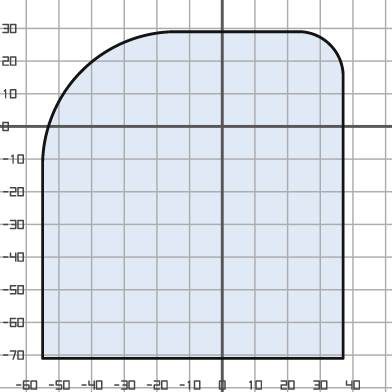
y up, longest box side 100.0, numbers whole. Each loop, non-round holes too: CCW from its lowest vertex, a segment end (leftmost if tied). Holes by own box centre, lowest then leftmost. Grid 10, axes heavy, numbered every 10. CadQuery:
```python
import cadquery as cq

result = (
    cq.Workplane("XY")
    .moveTo(-55.0, -71.0)
    .lineTo(37.0, -71.0)
    .lineTo(37.0, 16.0)
    .threePointArc((33.0, 25.0), (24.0, 29.0))
    .lineTo(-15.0, 29.0)
    .threePointArc((-43.0, 17.0), (-55.0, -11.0))
    .close()
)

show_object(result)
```